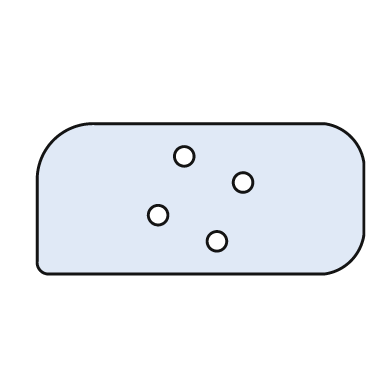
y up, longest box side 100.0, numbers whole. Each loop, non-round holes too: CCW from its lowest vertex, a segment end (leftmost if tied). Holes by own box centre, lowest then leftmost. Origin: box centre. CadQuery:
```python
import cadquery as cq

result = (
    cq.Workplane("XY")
    .moveTo(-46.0, -23.0)
    .lineTo(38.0, -23.0)
    .threePointArc((46.0, -19.0), (50.0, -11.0))
    .lineTo(50.0, 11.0)
    .threePointArc((46.0, 19.0), (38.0, 23.0))
    .lineTo(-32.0, 23.0)
    .threePointArc((-45.0, 18.0), (-50.0, 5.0))
    .lineTo(-50.0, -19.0)
    .threePointArc((-49.0, -22.0), (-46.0, -23.0))
    .close()
    .moveTo(5.0, -13.0)
    .circle(3.0)
    .moveTo(-13.0, -5.0)
    .circle(3.0)
    .moveTo(13.0, 5.0)
    .circle(3.0)
    .moveTo(-5.0, 13.0)
    .circle(3.0)
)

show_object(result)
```